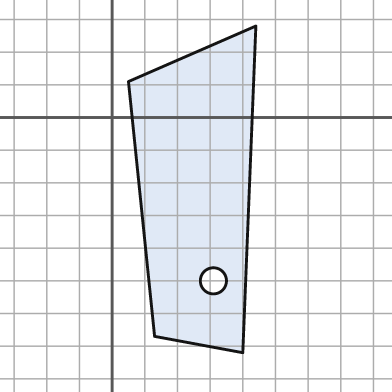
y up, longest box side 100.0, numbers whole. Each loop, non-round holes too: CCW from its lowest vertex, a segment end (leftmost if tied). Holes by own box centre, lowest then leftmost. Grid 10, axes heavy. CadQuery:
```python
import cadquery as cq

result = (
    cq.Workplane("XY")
    .moveTo(40.0, -72.0)
    .lineTo(44.0, 28.0)
    .lineTo(5.0, 11.0)
    .lineTo(13.0, -67.0)
    .close()
    .moveTo(31.0, -50.0)
    .circle(4.0)
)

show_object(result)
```